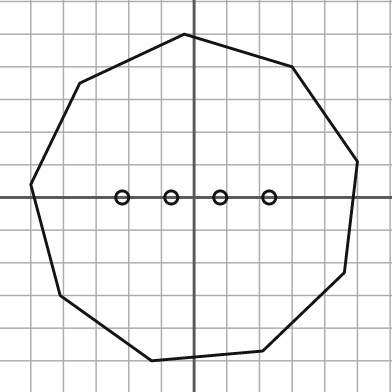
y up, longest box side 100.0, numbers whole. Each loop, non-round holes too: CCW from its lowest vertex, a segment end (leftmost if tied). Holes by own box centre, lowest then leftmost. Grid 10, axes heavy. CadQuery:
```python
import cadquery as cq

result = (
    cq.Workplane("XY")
    .moveTo(-13.0, -50.0)
    .lineTo(21.0, -47.0)
    .lineTo(46.0, -23.0)
    .lineTo(50.0, 11.0)
    .lineTo(30.0, 40.0)
    .lineTo(-3.0, 50.0)
    .lineTo(-35.0, 35.0)
    .lineTo(-50.0, 4.0)
    .lineTo(-41.0, -30.0)
    .close()
    .moveTo(-22.0, 0.0)
    .circle(2.0)
    .moveTo(-7.0, 0.0)
    .circle(2.0)
    .moveTo(8.0, 0.0)
    .circle(2.0)
    .moveTo(23.0, 0.0)
    .circle(2.0)
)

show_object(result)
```